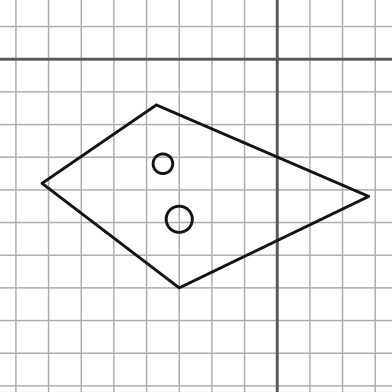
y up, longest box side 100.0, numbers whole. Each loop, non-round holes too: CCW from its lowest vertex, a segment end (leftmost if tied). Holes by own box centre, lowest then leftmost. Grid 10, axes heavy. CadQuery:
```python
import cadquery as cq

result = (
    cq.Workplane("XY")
    .moveTo(-30.0, -70.0)
    .lineTo(28.0, -42.0)
    .lineTo(-37.0, -14.0)
    .lineTo(-72.0, -38.0)
    .close()
    .moveTo(-30.0, -49.0)
    .circle(4.0)
    .moveTo(-35.0, -32.0)
    .circle(3.0)
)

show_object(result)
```